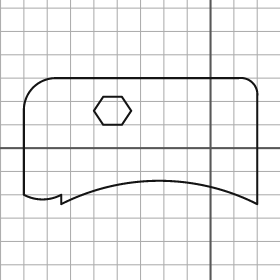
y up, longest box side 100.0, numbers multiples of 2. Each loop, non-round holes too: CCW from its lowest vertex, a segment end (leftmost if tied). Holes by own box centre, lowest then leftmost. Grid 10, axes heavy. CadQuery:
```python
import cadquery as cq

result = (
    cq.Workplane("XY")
    .moveTo(-64.0, -24.0)
    .threePointArc((-22.0, -14.0), (20.0, -24.0))
    .lineTo(20.0, 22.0)
    .threePointArc((18.0, 28.0), (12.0, 30.0))
    .lineTo(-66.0, 30.0)
    .threePointArc((-76.0, 26.0), (-80.0, 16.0))
    .lineTo(-80.0, -20.0)
    .threePointArc((-72.0, -22.0), (-64.0, -20.0))
    .close()
    .moveTo(-46.0, 10.0)
    .lineTo(-38.0, 10.0)
    .lineTo(-34.0, 16.0)
    .lineTo(-38.0, 22.0)
    .lineTo(-46.0, 22.0)
    .lineTo(-50.0, 16.0)
    .close()
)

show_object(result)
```